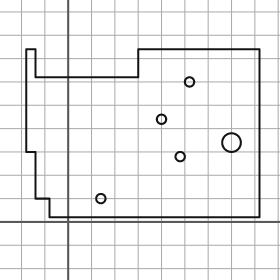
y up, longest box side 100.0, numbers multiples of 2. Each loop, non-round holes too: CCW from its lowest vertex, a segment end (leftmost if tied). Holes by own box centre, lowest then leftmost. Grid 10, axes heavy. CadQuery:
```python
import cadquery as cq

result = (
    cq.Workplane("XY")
    .moveTo(-8.0, 2.0)
    .lineTo(82.0, 2.0)
    .lineTo(82.0, 74.0)
    .lineTo(30.0, 74.0)
    .lineTo(30.0, 62.0)
    .lineTo(-14.0, 62.0)
    .lineTo(-14.0, 74.0)
    .lineTo(-18.0, 74.0)
    .lineTo(-18.0, 30.0)
    .lineTo(-14.0, 30.0)
    .lineTo(-14.0, 10.0)
    .lineTo(-8.0, 10.0)
    .close()
    .moveTo(14.0, 10.0)
    .circle(2.0)
    .moveTo(48.0, 28.0)
    .circle(2.0)
    .moveTo(70.0, 34.0)
    .circle(4.0)
    .moveTo(40.0, 44.0)
    .circle(2.0)
    .moveTo(52.0, 60.0)
    .circle(2.0)
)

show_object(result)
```